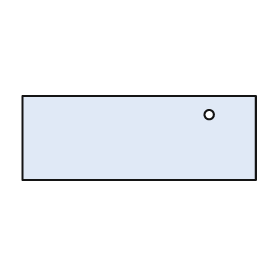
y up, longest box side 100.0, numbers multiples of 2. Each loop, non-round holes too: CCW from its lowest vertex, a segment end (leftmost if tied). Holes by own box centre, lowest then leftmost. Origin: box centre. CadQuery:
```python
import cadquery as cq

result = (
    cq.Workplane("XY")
    .moveTo(-50.0, -18.0)
    .lineTo(50.0, -18.0)
    .lineTo(50.0, 18.0)
    .lineTo(-50.0, 18.0)
    .close()
    .moveTo(30.0, 10.0)
    .circle(2.0)
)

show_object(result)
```